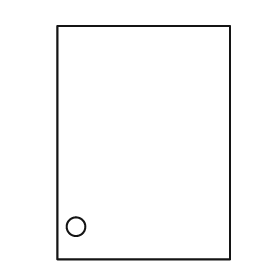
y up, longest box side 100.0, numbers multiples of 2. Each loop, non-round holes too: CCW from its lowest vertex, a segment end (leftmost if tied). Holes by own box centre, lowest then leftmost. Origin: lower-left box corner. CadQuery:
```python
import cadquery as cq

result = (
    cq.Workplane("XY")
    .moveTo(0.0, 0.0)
    .lineTo(74.0, 0.0)
    .lineTo(74.0, 100.0)
    .lineTo(0.0, 100.0)
    .close()
    .moveTo(8.0, 14.0)
    .circle(4.0)
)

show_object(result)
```